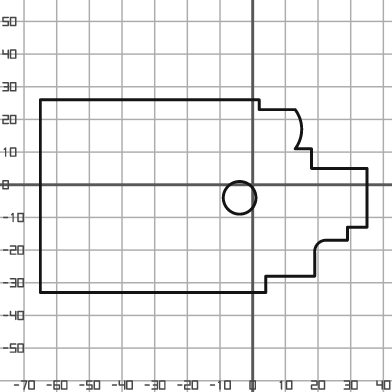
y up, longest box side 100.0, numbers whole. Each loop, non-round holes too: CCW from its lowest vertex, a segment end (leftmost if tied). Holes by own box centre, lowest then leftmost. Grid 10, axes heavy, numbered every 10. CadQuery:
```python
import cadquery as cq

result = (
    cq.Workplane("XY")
    .moveTo(-65.0, -33.0)
    .lineTo(4.0, -33.0)
    .lineTo(4.0, -28.0)
    .lineTo(19.0, -28.0)
    .lineTo(19.0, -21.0)
    .threePointArc((20.0, -18.0), (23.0, -17.0))
    .lineTo(29.0, -17.0)
    .lineTo(29.0, -13.0)
    .lineTo(35.0, -13.0)
    .lineTo(35.0, 5.0)
    .lineTo(18.0, 5.0)
    .lineTo(18.0, 11.0)
    .lineTo(13.0, 11.0)
    .threePointArc((15.0, 17.0), (13.0, 23.0))
    .lineTo(2.0, 23.0)
    .lineTo(2.0, 26.0)
    .lineTo(-65.0, 26.0)
    .close()
    .moveTo(-4.0, -4.0)
    .circle(5.0)
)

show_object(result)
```